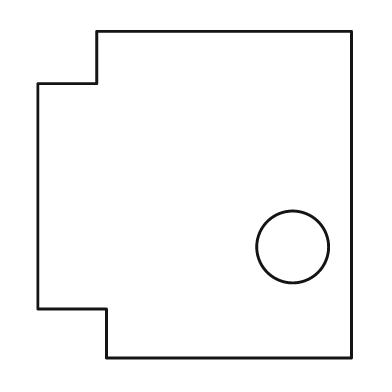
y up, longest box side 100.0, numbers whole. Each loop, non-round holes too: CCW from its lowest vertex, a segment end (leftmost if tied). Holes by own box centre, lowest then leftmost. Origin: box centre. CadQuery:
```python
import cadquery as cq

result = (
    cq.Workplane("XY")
    .moveTo(-27.0, -50.0)
    .lineTo(48.0, -50.0)
    .lineTo(48.0, 50.0)
    .lineTo(-30.0, 50.0)
    .lineTo(-30.0, 34.0)
    .lineTo(-48.0, 34.0)
    .lineTo(-48.0, -35.0)
    .lineTo(-27.0, -35.0)
    .close()
    .moveTo(30.0, -16.0)
    .circle(11.0)
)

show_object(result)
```